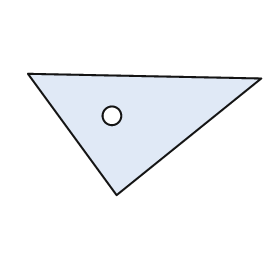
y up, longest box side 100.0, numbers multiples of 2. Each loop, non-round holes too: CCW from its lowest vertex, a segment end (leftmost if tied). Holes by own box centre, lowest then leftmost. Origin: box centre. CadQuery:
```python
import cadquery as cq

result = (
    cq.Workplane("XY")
    .moveTo(-12.0, -26.0)
    .lineTo(50.0, 24.0)
    .lineTo(-50.0, 26.0)
    .close()
    .moveTo(-14.0, 8.0)
    .circle(4.0)
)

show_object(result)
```